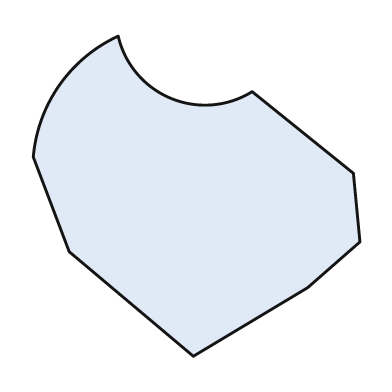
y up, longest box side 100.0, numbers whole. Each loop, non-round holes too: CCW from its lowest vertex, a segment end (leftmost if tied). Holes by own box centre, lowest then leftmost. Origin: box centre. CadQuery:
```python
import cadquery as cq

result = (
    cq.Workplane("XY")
    .moveTo(-1.0, -49.0)
    .lineTo(34.0, -28.0)
    .lineTo(50.0, -14.0)
    .lineTo(48.0, 7.0)
    .lineTo(17.0, 32.0)
    .threePointArc((-8.0, 30.0), (-24.0, 49.0))
    .threePointArc((-42.0, 34.0), (-50.0, 12.0))
    .lineTo(-39.0, -17.0)
    .close()
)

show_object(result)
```